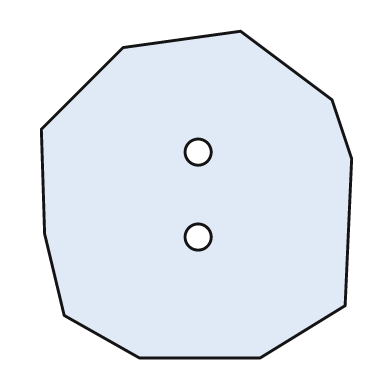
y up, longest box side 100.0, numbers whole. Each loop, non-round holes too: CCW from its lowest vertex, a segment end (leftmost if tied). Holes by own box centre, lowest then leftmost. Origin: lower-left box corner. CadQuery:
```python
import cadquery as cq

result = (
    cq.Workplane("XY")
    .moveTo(30.0, 0.0)
    .lineTo(67.0, 0.0)
    .lineTo(93.0, 16.0)
    .lineTo(95.0, 61.0)
    .lineTo(89.0, 79.0)
    .lineTo(61.0, 100.0)
    .lineTo(25.0, 95.0)
    .lineTo(0.0, 70.0)
    .lineTo(1.0, 38.0)
    .lineTo(7.0, 13.0)
    .close()
    .moveTo(48.0, 37.0)
    .circle(4.0)
    .moveTo(48.0, 63.0)
    .circle(4.0)
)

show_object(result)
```